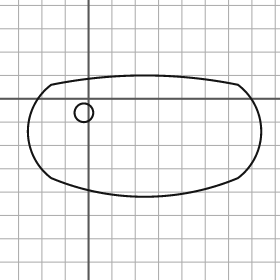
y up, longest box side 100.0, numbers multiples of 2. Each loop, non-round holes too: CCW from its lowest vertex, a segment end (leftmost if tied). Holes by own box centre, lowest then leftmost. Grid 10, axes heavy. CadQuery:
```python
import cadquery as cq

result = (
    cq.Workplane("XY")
    .moveTo(-16.0, -34.0)
    .threePointArc((24.0, -42.0), (64.0, -34.0))
    .threePointArc((74.0, -14.0), (64.0, 6.0))
    .threePointArc((24.0, 10.0), (-16.0, 6.0))
    .threePointArc((-26.0, -14.0), (-16.0, -34.0))
    .close()
    .moveTo(-2.0, -6.0)
    .circle(4.0)
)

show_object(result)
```